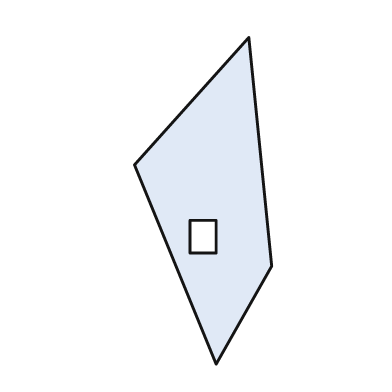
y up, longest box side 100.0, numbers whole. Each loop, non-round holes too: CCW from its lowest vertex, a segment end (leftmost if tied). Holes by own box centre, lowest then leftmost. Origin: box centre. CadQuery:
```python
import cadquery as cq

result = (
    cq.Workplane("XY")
    .moveTo(4.0, -50.0)
    .lineTo(21.0, -20.0)
    .lineTo(14.0, 50.0)
    .lineTo(-21.0, 11.0)
    .close()
    .moveTo(-4.0, -16.0)
    .lineTo(4.0, -16.0)
    .lineTo(4.0, -6.0)
    .lineTo(-4.0, -6.0)
    .close()
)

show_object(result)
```